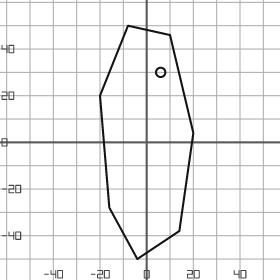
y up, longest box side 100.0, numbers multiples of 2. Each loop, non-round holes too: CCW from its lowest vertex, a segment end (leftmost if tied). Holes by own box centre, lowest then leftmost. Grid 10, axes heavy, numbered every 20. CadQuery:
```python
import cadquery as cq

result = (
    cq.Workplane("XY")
    .moveTo(-4.0, -50.0)
    .lineTo(14.0, -38.0)
    .lineTo(20.0, 4.0)
    .lineTo(10.0, 46.0)
    .lineTo(-8.0, 50.0)
    .lineTo(-20.0, 20.0)
    .lineTo(-16.0, -28.0)
    .close()
    .moveTo(6.0, 30.0)
    .circle(2.0)
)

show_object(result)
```